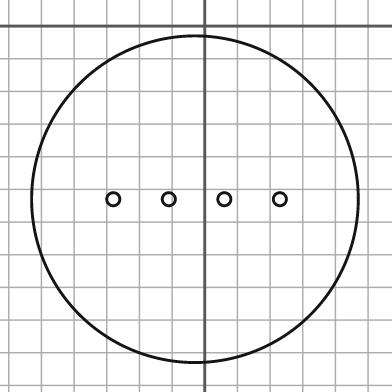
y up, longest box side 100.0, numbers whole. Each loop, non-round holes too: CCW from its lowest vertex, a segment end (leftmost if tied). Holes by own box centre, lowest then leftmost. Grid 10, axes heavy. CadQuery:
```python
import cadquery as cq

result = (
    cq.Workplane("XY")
    .moveTo(-3.0, -53.0)
    .circle(50.0)
    .moveTo(-28.0, -53.0)
    .circle(2.0)
    .moveTo(-11.0, -53.0)
    .circle(2.0)
    .moveTo(6.0, -53.0)
    .circle(2.0)
    .moveTo(23.0, -53.0)
    .circle(2.0)
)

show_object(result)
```